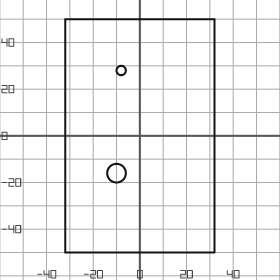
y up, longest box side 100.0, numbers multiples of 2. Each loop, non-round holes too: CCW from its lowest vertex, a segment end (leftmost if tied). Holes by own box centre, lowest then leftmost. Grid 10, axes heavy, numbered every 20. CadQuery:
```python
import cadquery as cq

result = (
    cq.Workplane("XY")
    .moveTo(-32.0, -50.0)
    .lineTo(32.0, -50.0)
    .lineTo(32.0, 50.0)
    .lineTo(-32.0, 50.0)
    .close()
    .moveTo(-10.0, -16.0)
    .circle(4.0)
    .moveTo(-8.0, 28.0)
    .circle(2.0)
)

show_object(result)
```